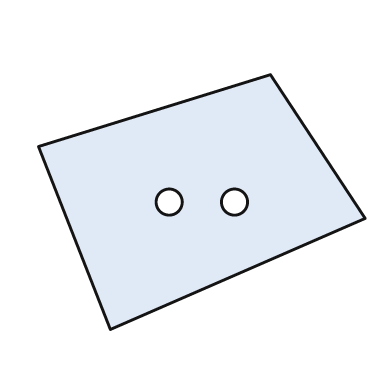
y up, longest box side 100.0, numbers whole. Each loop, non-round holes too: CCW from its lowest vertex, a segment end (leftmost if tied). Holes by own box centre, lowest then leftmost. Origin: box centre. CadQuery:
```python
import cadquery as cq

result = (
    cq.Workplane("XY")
    .moveTo(-28.0, -39.0)
    .lineTo(50.0, -5.0)
    .lineTo(21.0, 39.0)
    .lineTo(-50.0, 17.0)
    .close()
    .moveTo(-10.0, 0.0)
    .circle(4.0)
    .moveTo(10.0, 0.0)
    .circle(4.0)
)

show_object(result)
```